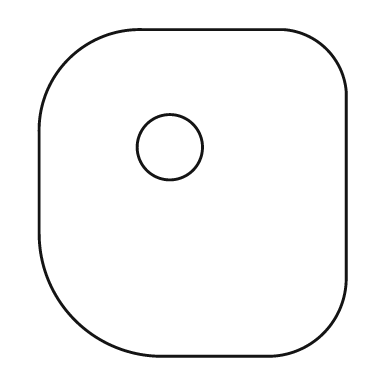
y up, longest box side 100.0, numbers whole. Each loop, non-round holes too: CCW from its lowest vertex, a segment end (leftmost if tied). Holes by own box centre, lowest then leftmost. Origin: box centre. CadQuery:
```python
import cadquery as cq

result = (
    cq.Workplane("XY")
    .moveTo(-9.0, -50.0)
    .lineTo(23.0, -50.0)
    .threePointArc((40.0, -43.0), (47.0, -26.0))
    .lineTo(47.0, 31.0)
    .threePointArc((41.0, 44.0), (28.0, 50.0))
    .lineTo(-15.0, 50.0)
    .threePointArc((-38.0, 41.0), (-47.0, 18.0))
    .lineTo(-47.0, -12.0)
    .threePointArc((-36.0, -39.0), (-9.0, -50.0))
    .close()
    .moveTo(-7.0, 14.0)
    .circle(10.0)
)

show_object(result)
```